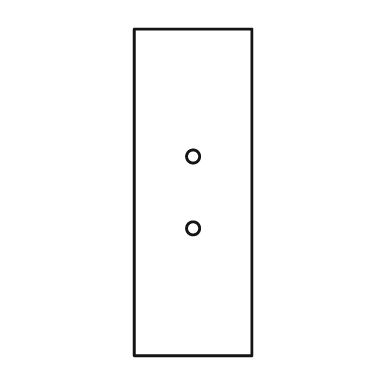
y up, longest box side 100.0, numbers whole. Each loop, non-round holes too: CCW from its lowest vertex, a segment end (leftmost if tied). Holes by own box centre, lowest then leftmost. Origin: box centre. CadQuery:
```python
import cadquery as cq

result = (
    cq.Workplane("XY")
    .moveTo(-18.0, -50.0)
    .lineTo(18.0, -50.0)
    .lineTo(18.0, 50.0)
    .lineTo(-18.0, 50.0)
    .close()
    .moveTo(0.0, -11.0)
    .circle(2.0)
    .moveTo(0.0, 11.0)
    .circle(2.0)
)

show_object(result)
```